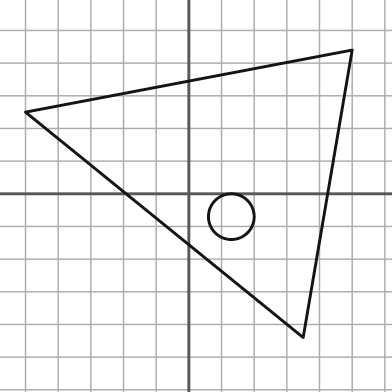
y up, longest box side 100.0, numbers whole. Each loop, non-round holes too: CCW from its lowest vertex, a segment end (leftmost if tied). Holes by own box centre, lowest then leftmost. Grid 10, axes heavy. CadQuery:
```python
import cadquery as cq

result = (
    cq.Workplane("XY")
    .moveTo(35.0, -44.0)
    .lineTo(50.0, 44.0)
    .lineTo(-50.0, 25.0)
    .close()
    .moveTo(13.0, -7.0)
    .circle(7.0)
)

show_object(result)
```